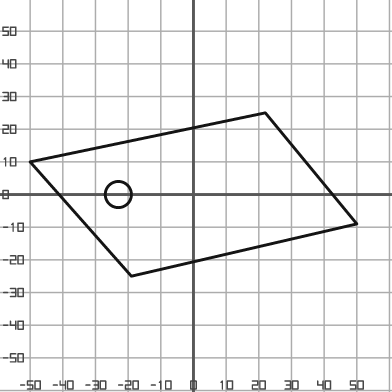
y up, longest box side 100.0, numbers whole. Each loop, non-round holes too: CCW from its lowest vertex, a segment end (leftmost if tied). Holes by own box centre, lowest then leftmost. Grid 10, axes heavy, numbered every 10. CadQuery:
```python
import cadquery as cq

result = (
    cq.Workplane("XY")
    .moveTo(-19.0, -25.0)
    .lineTo(50.0, -9.0)
    .lineTo(22.0, 25.0)
    .lineTo(-50.0, 10.0)
    .close()
    .moveTo(-23.0, 0.0)
    .circle(4.0)
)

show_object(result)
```